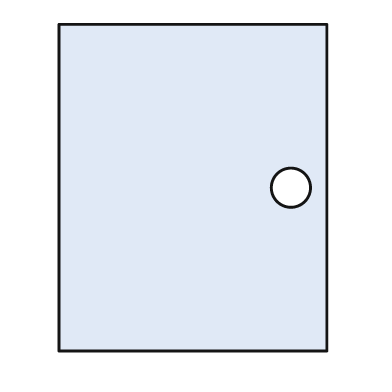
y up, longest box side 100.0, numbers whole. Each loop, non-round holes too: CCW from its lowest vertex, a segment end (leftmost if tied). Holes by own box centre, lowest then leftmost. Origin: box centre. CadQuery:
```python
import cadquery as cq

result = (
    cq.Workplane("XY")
    .moveTo(-41.0, -50.0)
    .lineTo(41.0, -50.0)
    .lineTo(41.0, 50.0)
    .lineTo(-41.0, 50.0)
    .close()
    .moveTo(30.0, 0.0)
    .circle(6.0)
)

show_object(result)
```